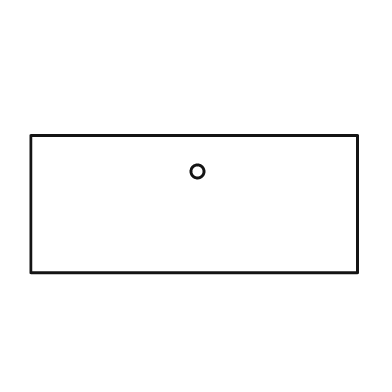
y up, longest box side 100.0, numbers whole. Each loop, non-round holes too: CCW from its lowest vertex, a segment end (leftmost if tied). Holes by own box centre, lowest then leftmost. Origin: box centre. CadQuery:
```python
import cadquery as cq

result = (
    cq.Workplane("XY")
    .moveTo(-50.0, -21.0)
    .lineTo(50.0, -21.0)
    .lineTo(50.0, 21.0)
    .lineTo(-50.0, 21.0)
    .close()
    .moveTo(1.0, 10.0)
    .circle(2.0)
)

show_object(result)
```